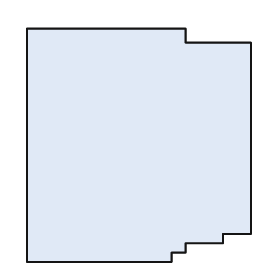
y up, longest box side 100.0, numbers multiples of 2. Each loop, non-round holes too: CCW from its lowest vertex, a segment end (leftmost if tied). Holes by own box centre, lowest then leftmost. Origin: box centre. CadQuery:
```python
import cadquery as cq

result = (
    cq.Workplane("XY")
    .moveTo(-48.0, -50.0)
    .lineTo(14.0, -50.0)
    .lineTo(14.0, -46.0)
    .lineTo(20.0, -46.0)
    .lineTo(20.0, -42.0)
    .lineTo(36.0, -42.0)
    .lineTo(36.0, -38.0)
    .lineTo(48.0, -38.0)
    .lineTo(48.0, 44.0)
    .lineTo(20.0, 44.0)
    .lineTo(20.0, 50.0)
    .lineTo(-48.0, 50.0)
    .close()
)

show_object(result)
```